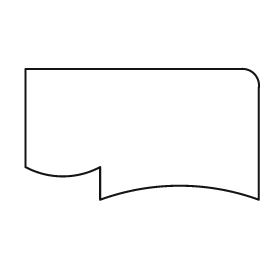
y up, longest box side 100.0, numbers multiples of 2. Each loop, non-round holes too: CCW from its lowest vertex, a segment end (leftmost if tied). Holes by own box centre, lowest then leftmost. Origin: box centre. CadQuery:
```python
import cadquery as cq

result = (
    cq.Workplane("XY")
    .moveTo(-18.0, -28.0)
    .threePointArc((16.0, -22.0), (50.0, -28.0))
    .lineTo(50.0, 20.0)
    .threePointArc((48.0, 26.0), (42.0, 28.0))
    .lineTo(-50.0, 28.0)
    .lineTo(-50.0, -14.0)
    .threePointArc((-34.0, -18.0), (-18.0, -14.0))
    .close()
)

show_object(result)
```